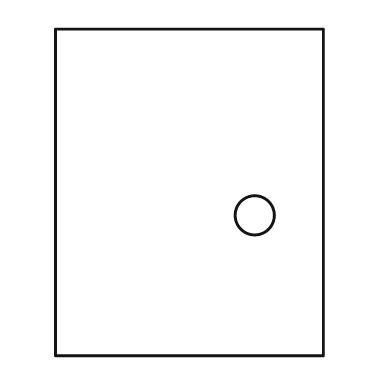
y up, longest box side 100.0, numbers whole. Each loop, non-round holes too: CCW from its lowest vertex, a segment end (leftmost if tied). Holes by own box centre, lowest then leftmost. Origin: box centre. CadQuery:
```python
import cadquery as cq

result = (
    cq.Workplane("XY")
    .moveTo(-41.0, -50.0)
    .lineTo(41.0, -50.0)
    .lineTo(41.0, 50.0)
    .lineTo(-41.0, 50.0)
    .close()
    .moveTo(20.0, -7.0)
    .circle(6.0)
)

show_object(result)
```